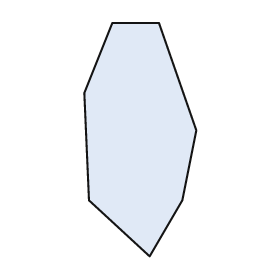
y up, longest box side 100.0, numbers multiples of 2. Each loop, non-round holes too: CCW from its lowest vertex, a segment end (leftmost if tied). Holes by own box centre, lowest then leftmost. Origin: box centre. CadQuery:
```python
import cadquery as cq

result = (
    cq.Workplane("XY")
    .moveTo(4.0, -50.0)
    .lineTo(18.0, -26.0)
    .lineTo(24.0, 4.0)
    .lineTo(8.0, 50.0)
    .lineTo(-12.0, 50.0)
    .lineTo(-24.0, 20.0)
    .lineTo(-22.0, -26.0)
    .close()
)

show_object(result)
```